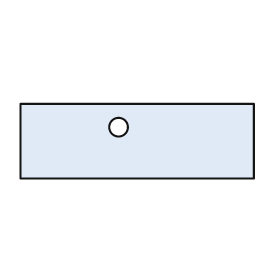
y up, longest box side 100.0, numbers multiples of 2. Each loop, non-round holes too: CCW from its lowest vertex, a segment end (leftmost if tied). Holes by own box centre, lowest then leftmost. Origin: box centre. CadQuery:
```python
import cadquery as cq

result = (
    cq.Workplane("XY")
    .moveTo(-50.0, -16.0)
    .lineTo(50.0, -16.0)
    .lineTo(50.0, 16.0)
    .lineTo(-50.0, 16.0)
    .close()
    .moveTo(-8.0, 6.0)
    .circle(4.0)
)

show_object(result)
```